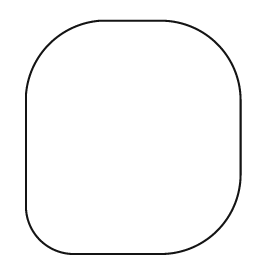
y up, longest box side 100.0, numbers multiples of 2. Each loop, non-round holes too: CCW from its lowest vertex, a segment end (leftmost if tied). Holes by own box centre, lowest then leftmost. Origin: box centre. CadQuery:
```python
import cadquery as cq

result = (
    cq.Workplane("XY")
    .moveTo(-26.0, -50.0)
    .lineTo(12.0, -50.0)
    .threePointArc((36.0, -40.0), (46.0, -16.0))
    .lineTo(46.0, 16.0)
    .threePointArc((36.0, 40.0), (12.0, 50.0))
    .lineTo(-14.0, 50.0)
    .threePointArc((-36.0, 40.0), (-46.0, 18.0))
    .lineTo(-46.0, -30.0)
    .threePointArc((-40.0, -44.0), (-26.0, -50.0))
    .close()
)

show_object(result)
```